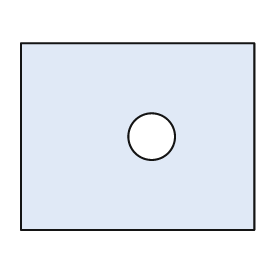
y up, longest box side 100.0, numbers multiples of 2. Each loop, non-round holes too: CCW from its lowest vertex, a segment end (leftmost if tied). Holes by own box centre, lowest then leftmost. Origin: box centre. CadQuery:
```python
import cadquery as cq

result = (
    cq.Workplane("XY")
    .moveTo(-50.0, -40.0)
    .lineTo(50.0, -40.0)
    .lineTo(50.0, 40.0)
    .lineTo(-50.0, 40.0)
    .close()
    .moveTo(6.0, 0.0)
    .circle(10.0)
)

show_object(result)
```